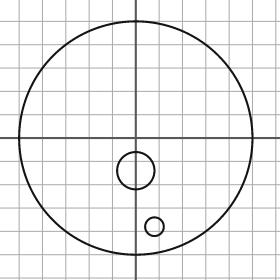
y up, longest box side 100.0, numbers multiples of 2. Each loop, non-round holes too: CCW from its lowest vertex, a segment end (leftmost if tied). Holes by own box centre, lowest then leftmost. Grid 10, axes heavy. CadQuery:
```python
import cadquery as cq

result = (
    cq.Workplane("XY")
    .moveTo(0.0, 0.0)
    .circle(50.0)
    .moveTo(8.0, -38.0)
    .circle(4.0)
    .moveTo(0.0, -14.0)
    .circle(8.0)
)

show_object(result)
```